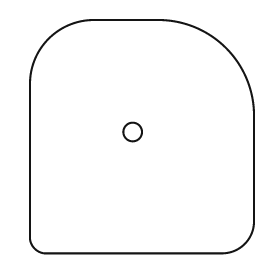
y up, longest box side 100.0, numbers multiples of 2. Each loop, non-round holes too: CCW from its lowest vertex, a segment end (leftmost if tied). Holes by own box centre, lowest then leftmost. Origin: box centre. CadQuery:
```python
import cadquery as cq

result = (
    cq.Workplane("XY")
    .moveTo(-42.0, -50.0)
    .lineTo(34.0, -50.0)
    .threePointArc((44.0, -46.0), (48.0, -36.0))
    .lineTo(48.0, 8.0)
    .threePointArc((36.0, 38.0), (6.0, 50.0))
    .lineTo(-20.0, 50.0)
    .threePointArc((-40.0, 42.0), (-48.0, 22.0))
    .lineTo(-48.0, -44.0)
    .threePointArc((-46.0, -48.0), (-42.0, -50.0))
    .close()
    .moveTo(-4.0, 2.0)
    .circle(4.0)
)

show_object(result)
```